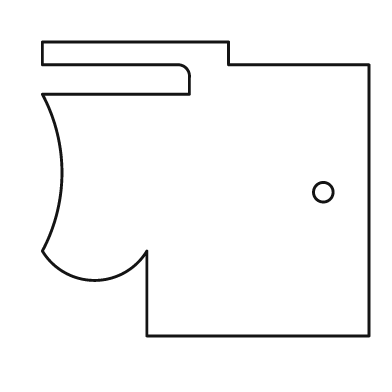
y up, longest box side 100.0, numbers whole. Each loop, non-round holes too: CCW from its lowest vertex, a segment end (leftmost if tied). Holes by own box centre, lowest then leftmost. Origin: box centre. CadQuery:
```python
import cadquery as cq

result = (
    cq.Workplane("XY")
    .moveTo(-18.0, -45.0)
    .lineTo(50.0, -45.0)
    .lineTo(50.0, 38.0)
    .lineTo(7.0, 38.0)
    .lineTo(7.0, 45.0)
    .lineTo(-50.0, 45.0)
    .lineTo(-50.0, 38.0)
    .lineTo(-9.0, 38.0)
    .threePointArc((-6.0, 37.0), (-5.0, 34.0))
    .lineTo(-5.0, 29.0)
    .lineTo(-50.0, 29.0)
    .threePointArc((-44.0, 5.0), (-50.0, -19.0))
    .threePointArc((-34.0, -28.0), (-18.0, -19.0))
    .close()
    .moveTo(36.0, -1.0)
    .circle(3.0)
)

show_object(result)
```